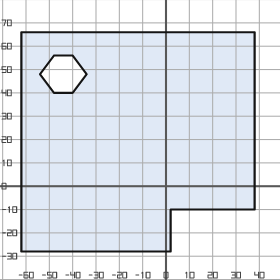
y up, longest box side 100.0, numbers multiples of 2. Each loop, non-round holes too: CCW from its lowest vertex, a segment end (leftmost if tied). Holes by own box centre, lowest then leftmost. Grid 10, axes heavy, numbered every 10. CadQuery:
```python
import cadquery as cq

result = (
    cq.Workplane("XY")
    .moveTo(-62.0, -28.0)
    .lineTo(2.0, -28.0)
    .lineTo(2.0, -10.0)
    .lineTo(38.0, -10.0)
    .lineTo(38.0, 66.0)
    .lineTo(-62.0, 66.0)
    .close()
    .moveTo(-48.0, 40.0)
    .lineTo(-40.0, 40.0)
    .lineTo(-34.0, 48.0)
    .lineTo(-40.0, 56.0)
    .lineTo(-48.0, 56.0)
    .lineTo(-54.0, 48.0)
    .close()
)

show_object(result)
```